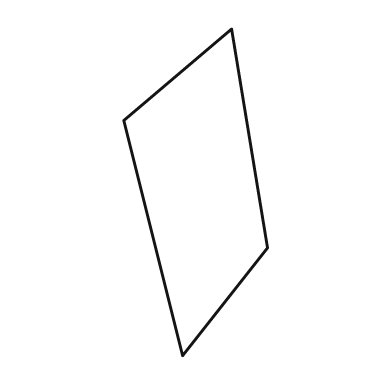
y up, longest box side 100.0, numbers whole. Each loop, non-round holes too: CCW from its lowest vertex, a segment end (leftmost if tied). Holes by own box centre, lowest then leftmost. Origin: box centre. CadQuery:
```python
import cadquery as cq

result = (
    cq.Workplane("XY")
    .moveTo(-4.0, -50.0)
    .lineTo(22.0, -17.0)
    .lineTo(11.0, 50.0)
    .lineTo(-22.0, 22.0)
    .close()
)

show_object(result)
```